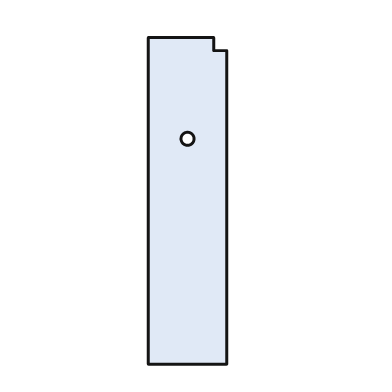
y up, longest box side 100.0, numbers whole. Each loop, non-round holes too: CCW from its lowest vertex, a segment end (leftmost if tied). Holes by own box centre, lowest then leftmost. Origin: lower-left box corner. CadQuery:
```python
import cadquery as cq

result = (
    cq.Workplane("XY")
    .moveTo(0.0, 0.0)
    .lineTo(24.0, 0.0)
    .lineTo(24.0, 96.0)
    .lineTo(20.0, 96.0)
    .lineTo(20.0, 100.0)
    .lineTo(0.0, 100.0)
    .close()
    .moveTo(12.0, 69.0)
    .circle(2.0)
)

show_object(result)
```